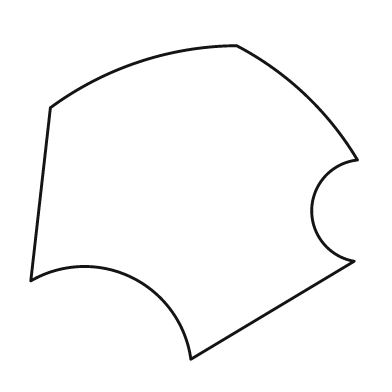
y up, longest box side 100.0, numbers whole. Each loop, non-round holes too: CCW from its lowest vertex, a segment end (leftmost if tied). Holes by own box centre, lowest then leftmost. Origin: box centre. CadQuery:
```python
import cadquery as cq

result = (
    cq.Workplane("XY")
    .moveTo(-1.0, -48.0)
    .lineTo(49.0, -18.0)
    .threePointArc((36.0, -2.0), (50.0, 13.0))
    .threePointArc((34.0, 33.0), (13.0, 48.0))
    .threePointArc((-17.0, 43.0), (-44.0, 29.0))
    .lineTo(-50.0, -24.0)
    .threePointArc((-19.0, -23.0), (-1.0, -48.0))
    .close()
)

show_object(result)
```